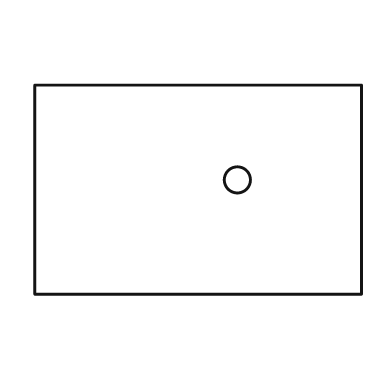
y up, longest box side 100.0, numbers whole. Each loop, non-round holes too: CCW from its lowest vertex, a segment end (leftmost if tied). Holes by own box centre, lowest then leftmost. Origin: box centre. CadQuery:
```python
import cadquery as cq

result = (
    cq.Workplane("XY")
    .moveTo(-50.0, -32.0)
    .lineTo(50.0, -32.0)
    .lineTo(50.0, 32.0)
    .lineTo(-50.0, 32.0)
    .close()
    .moveTo(12.0, 3.0)
    .circle(4.0)
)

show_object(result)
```